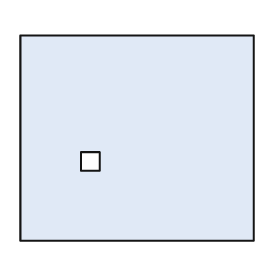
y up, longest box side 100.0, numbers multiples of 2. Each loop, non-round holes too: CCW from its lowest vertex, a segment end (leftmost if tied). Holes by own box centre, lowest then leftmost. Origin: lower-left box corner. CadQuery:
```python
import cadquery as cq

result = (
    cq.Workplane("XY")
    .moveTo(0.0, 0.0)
    .lineTo(100.0, 0.0)
    .lineTo(100.0, 88.0)
    .lineTo(0.0, 88.0)
    .close()
    .moveTo(26.0, 30.0)
    .lineTo(34.0, 30.0)
    .lineTo(34.0, 38.0)
    .lineTo(26.0, 38.0)
    .close()
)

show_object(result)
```